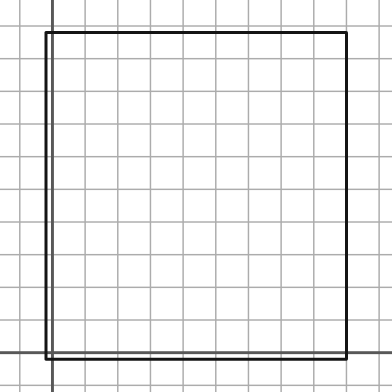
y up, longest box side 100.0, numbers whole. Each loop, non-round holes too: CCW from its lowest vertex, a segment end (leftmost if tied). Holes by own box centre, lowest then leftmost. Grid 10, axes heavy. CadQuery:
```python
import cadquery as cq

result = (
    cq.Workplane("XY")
    .moveTo(-2.0, -2.0)
    .lineTo(90.0, -2.0)
    .lineTo(90.0, 98.0)
    .lineTo(-2.0, 98.0)
    .close()
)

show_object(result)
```